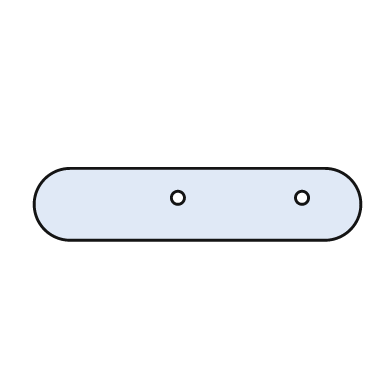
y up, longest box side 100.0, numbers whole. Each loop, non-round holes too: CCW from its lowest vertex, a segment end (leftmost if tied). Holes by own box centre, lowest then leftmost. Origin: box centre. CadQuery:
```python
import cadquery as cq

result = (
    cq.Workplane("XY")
    .moveTo(-39.0, -11.0)
    .lineTo(39.0, -11.0)
    .threePointArc((50.0, 0.0), (39.0, 11.0))
    .lineTo(-39.0, 11.0)
    .threePointArc((-50.0, 0.0), (-39.0, -11.0))
    .close()
    .moveTo(-6.0, 2.0)
    .circle(2.0)
    .moveTo(32.0, 2.0)
    .circle(2.0)
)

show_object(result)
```